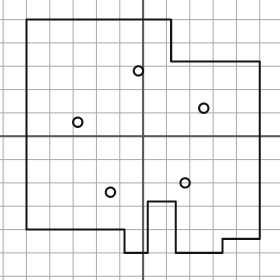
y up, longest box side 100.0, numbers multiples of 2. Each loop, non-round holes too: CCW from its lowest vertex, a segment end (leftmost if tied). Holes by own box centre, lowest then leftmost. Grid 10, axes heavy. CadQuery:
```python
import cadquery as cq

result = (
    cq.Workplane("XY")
    .moveTo(-8.0, -50.0)
    .lineTo(2.0, -50.0)
    .lineTo(2.0, -28.0)
    .lineTo(14.0, -28.0)
    .lineTo(14.0, -50.0)
    .lineTo(34.0, -50.0)
    .lineTo(34.0, -44.0)
    .lineTo(50.0, -44.0)
    .lineTo(50.0, 32.0)
    .lineTo(12.0, 32.0)
    .lineTo(12.0, 50.0)
    .lineTo(-50.0, 50.0)
    .lineTo(-50.0, -40.0)
    .lineTo(-8.0, -40.0)
    .close()
    .moveTo(-14.0, -24.0)
    .circle(2.0)
    .moveTo(18.0, -20.0)
    .circle(2.0)
    .moveTo(-28.0, 6.0)
    .circle(2.0)
    .moveTo(26.0, 12.0)
    .circle(2.0)
    .moveTo(-2.0, 28.0)
    .circle(2.0)
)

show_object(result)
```